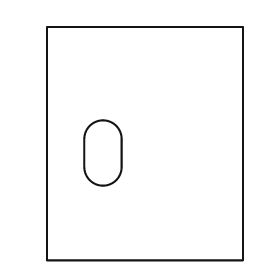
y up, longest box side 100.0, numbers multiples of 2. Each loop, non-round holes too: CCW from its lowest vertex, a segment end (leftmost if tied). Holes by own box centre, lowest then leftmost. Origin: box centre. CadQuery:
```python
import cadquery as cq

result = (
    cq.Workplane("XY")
    .moveTo(-42.0, -50.0)
    .lineTo(42.0, -50.0)
    .lineTo(42.0, 50.0)
    .lineTo(-42.0, 50.0)
    .close()
    .moveTo(-26.0, -10.0)
    .threePointArc((-18.0, -18.0), (-10.0, -10.0))
    .lineTo(-10.0, 2.0)
    .threePointArc((-18.0, 10.0), (-26.0, 2.0))
    .close()
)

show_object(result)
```